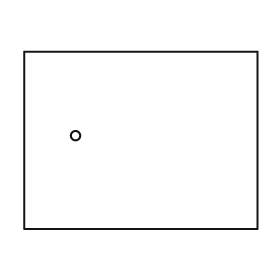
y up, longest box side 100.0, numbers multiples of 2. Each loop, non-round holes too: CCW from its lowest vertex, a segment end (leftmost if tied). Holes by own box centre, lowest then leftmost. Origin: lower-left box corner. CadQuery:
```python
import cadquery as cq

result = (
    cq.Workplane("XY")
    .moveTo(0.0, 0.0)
    .lineTo(100.0, 0.0)
    .lineTo(100.0, 76.0)
    .lineTo(0.0, 76.0)
    .close()
    .moveTo(22.0, 40.0)
    .circle(2.0)
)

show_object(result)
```